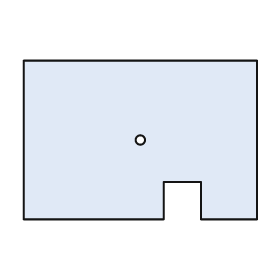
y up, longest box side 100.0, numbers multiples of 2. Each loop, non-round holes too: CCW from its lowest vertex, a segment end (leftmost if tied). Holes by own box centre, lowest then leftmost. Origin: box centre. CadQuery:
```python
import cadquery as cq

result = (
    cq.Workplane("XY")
    .moveTo(-50.0, -34.0)
    .lineTo(10.0, -34.0)
    .lineTo(10.0, -18.0)
    .lineTo(26.0, -18.0)
    .lineTo(26.0, -34.0)
    .lineTo(50.0, -34.0)
    .lineTo(50.0, 34.0)
    .lineTo(-50.0, 34.0)
    .close()
    .moveTo(0.0, 0.0)
    .circle(2.0)
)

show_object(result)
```